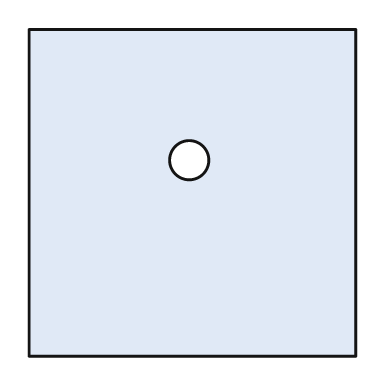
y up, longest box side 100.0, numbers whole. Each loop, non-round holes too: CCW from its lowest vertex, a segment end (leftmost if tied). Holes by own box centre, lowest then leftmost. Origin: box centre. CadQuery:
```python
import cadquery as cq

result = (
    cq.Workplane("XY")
    .moveTo(-50.0, -50.0)
    .lineTo(50.0, -50.0)
    .lineTo(50.0, 50.0)
    .lineTo(-50.0, 50.0)
    .close()
    .moveTo(-1.0, 10.0)
    .circle(6.0)
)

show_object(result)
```